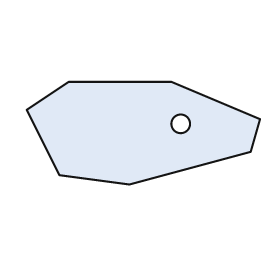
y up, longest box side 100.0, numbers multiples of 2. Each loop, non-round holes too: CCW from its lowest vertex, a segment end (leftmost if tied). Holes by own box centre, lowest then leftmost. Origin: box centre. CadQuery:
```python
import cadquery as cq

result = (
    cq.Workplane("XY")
    .moveTo(-6.0, -22.0)
    .lineTo(46.0, -8.0)
    .lineTo(50.0, 6.0)
    .lineTo(12.0, 22.0)
    .lineTo(-32.0, 22.0)
    .lineTo(-50.0, 10.0)
    .lineTo(-36.0, -18.0)
    .close()
    .moveTo(16.0, 4.0)
    .circle(4.0)
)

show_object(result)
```